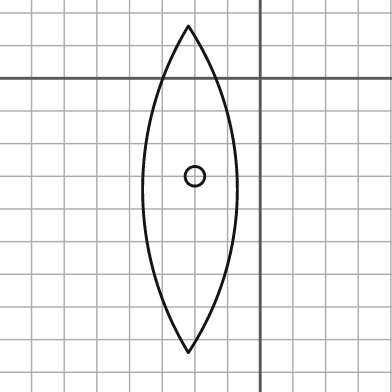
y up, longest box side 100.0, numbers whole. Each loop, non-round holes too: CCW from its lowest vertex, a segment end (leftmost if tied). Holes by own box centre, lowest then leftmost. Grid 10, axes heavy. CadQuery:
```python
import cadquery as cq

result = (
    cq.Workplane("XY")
    .moveTo(-22.0, -84.0)
    .threePointArc((-7.0, -34.0), (-22.0, 16.0))
    .threePointArc((-36.0, -34.0), (-22.0, -84.0))
    .close()
    .moveTo(-20.0, -30.0)
    .circle(3.0)
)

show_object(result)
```